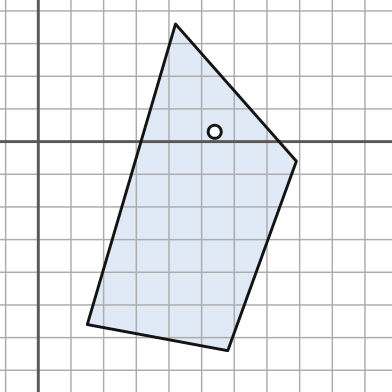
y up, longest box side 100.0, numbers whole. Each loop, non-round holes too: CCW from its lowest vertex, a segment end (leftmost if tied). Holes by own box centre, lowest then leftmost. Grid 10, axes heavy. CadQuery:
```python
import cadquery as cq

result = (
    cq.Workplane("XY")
    .moveTo(58.0, -64.0)
    .lineTo(79.0, -6.0)
    .lineTo(42.0, 36.0)
    .lineTo(15.0, -56.0)
    .close()
    .moveTo(54.0, 3.0)
    .circle(2.0)
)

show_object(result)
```